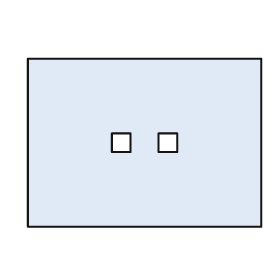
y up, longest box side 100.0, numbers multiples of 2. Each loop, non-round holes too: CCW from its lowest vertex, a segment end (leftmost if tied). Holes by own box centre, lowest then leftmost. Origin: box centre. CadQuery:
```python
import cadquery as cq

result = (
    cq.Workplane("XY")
    .moveTo(-50.0, -36.0)
    .lineTo(50.0, -36.0)
    .lineTo(50.0, 36.0)
    .lineTo(-50.0, 36.0)
    .close()
    .moveTo(-14.0, -4.0)
    .lineTo(-6.0, -4.0)
    .lineTo(-6.0, 4.0)
    .lineTo(-14.0, 4.0)
    .close()
    .moveTo(6.0, -4.0)
    .lineTo(14.0, -4.0)
    .lineTo(14.0, 4.0)
    .lineTo(6.0, 4.0)
    .close()
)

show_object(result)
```